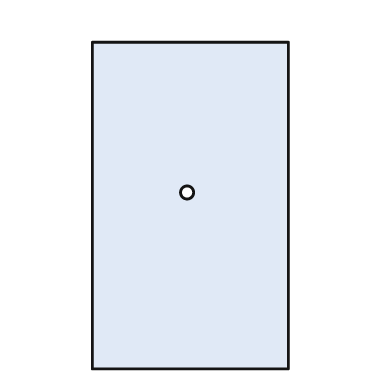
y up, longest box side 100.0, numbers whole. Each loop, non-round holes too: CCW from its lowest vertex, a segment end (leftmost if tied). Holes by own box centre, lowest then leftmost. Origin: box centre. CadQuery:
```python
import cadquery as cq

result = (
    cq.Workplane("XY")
    .moveTo(-30.0, -50.0)
    .lineTo(30.0, -50.0)
    .lineTo(30.0, 50.0)
    .lineTo(-30.0, 50.0)
    .close()
    .moveTo(-1.0, 4.0)
    .circle(2.0)
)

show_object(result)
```